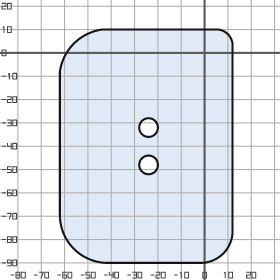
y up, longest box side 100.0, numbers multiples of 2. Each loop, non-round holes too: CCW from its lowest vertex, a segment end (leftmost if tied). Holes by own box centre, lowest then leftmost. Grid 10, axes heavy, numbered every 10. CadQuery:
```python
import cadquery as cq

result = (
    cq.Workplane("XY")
    .moveTo(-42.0, -90.0)
    .lineTo(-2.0, -90.0)
    .threePointArc((8.0, -86.0), (12.0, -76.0))
    .lineTo(12.0, 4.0)
    .threePointArc((10.0, 8.0), (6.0, 10.0))
    .lineTo(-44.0, 10.0)
    .threePointArc((-56.0, 4.0), (-62.0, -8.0))
    .lineTo(-62.0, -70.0)
    .threePointArc((-56.0, -84.0), (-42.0, -90.0))
    .close()
    .moveTo(-24.0, -48.0)
    .circle(4.0)
    .moveTo(-24.0, -32.0)
    .circle(4.0)
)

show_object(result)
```